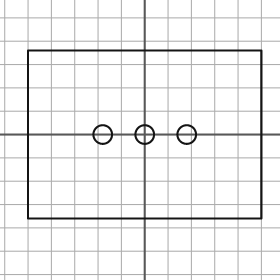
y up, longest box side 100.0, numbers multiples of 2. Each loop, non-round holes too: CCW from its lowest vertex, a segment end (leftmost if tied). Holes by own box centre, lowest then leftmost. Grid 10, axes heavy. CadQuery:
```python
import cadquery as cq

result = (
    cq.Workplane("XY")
    .moveTo(-50.0, -36.0)
    .lineTo(50.0, -36.0)
    .lineTo(50.0, 36.0)
    .lineTo(-50.0, 36.0)
    .close()
    .moveTo(-18.0, 0.0)
    .circle(4.0)
    .moveTo(0.0, 0.0)
    .circle(4.0)
    .moveTo(18.0, 0.0)
    .circle(4.0)
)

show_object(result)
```